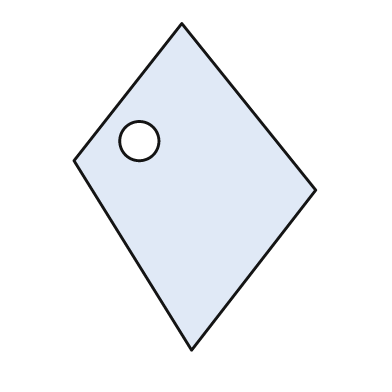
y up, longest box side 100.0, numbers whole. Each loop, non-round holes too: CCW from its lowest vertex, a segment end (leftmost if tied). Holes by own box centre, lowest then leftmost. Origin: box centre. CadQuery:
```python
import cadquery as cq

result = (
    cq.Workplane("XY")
    .moveTo(-1.0, -50.0)
    .lineTo(37.0, -1.0)
    .lineTo(-4.0, 50.0)
    .lineTo(-37.0, 8.0)
    .close()
    .moveTo(-17.0, 14.0)
    .circle(6.0)
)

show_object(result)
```